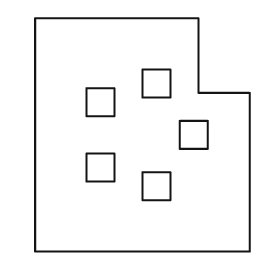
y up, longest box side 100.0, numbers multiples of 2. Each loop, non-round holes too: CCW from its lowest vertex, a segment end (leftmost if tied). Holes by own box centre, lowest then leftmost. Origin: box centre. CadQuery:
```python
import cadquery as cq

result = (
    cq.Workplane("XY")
    .moveTo(-46.0, -50.0)
    .lineTo(46.0, -50.0)
    .lineTo(46.0, 18.0)
    .lineTo(24.0, 18.0)
    .lineTo(24.0, 50.0)
    .lineTo(-46.0, 50.0)
    .close()
    .moveTo(0.0, -28.0)
    .lineTo(12.0, -28.0)
    .lineTo(12.0, -16.0)
    .lineTo(0.0, -16.0)
    .close()
    .moveTo(-24.0, -20.0)
    .lineTo(-12.0, -20.0)
    .lineTo(-12.0, -8.0)
    .lineTo(-24.0, -8.0)
    .close()
    .moveTo(16.0, -6.0)
    .lineTo(28.0, -6.0)
    .lineTo(28.0, 6.0)
    .lineTo(16.0, 6.0)
    .close()
    .moveTo(-24.0, 8.0)
    .lineTo(-12.0, 8.0)
    .lineTo(-12.0, 20.0)
    .lineTo(-24.0, 20.0)
    .close()
    .moveTo(0.0, 16.0)
    .lineTo(12.0, 16.0)
    .lineTo(12.0, 28.0)
    .lineTo(0.0, 28.0)
    .close()
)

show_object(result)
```